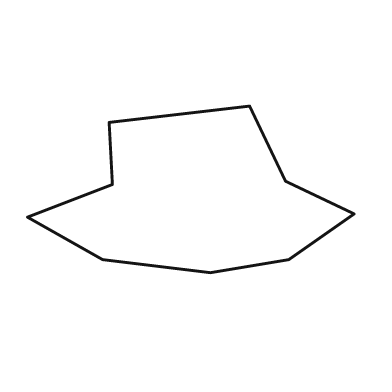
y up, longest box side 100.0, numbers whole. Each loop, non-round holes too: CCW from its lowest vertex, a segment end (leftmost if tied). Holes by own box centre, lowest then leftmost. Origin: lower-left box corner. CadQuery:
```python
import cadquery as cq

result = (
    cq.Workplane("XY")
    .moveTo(56.0, 0.0)
    .lineTo(80.0, 4.0)
    .lineTo(100.0, 18.0)
    .lineTo(79.0, 28.0)
    .lineTo(68.0, 51.0)
    .lineTo(25.0, 46.0)
    .lineTo(26.0, 27.0)
    .lineTo(0.0, 17.0)
    .lineTo(23.0, 4.0)
    .close()
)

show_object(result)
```